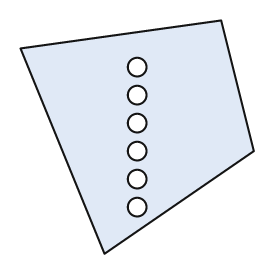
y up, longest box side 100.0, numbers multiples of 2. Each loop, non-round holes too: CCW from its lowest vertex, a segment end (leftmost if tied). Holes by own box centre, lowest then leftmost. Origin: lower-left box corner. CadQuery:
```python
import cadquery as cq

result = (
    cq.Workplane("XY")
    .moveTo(36.0, 0.0)
    .lineTo(100.0, 44.0)
    .lineTo(86.0, 100.0)
    .lineTo(0.0, 88.0)
    .close()
    .moveTo(50.0, 20.0)
    .circle(4.0)
    .moveTo(50.0, 32.0)
    .circle(4.0)
    .moveTo(50.0, 44.0)
    .circle(4.0)
    .moveTo(50.0, 56.0)
    .circle(4.0)
    .moveTo(50.0, 68.0)
    .circle(4.0)
    .moveTo(50.0, 80.0)
    .circle(4.0)
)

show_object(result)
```